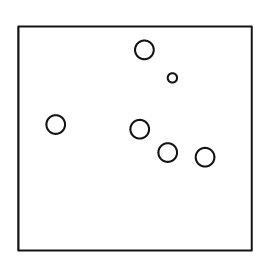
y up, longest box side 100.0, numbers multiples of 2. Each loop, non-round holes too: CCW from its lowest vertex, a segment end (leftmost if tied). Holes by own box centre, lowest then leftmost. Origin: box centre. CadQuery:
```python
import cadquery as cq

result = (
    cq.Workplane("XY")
    .moveTo(-50.0, -48.0)
    .lineTo(50.0, -48.0)
    .lineTo(50.0, 48.0)
    .lineTo(-50.0, 48.0)
    .close()
    .moveTo(30.0, -8.0)
    .circle(4.0)
    .moveTo(14.0, -6.0)
    .circle(4.0)
    .moveTo(2.0, 4.0)
    .circle(4.0)
    .moveTo(-34.0, 6.0)
    .circle(4.0)
    .moveTo(16.0, 26.0)
    .circle(2.0)
    .moveTo(4.0, 38.0)
    .circle(4.0)
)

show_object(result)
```